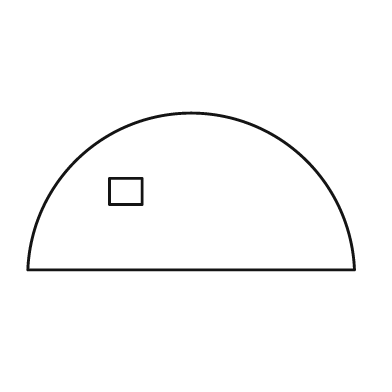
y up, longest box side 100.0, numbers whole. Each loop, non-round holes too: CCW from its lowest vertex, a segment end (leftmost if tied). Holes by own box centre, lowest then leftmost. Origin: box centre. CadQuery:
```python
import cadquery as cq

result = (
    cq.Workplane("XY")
    .moveTo(-50.0, -24.0)
    .lineTo(50.0, -24.0)
    .threePointArc((0.0, 24.0), (-50.0, -24.0))
    .close()
    .moveTo(-25.0, -4.0)
    .lineTo(-15.0, -4.0)
    .lineTo(-15.0, 4.0)
    .lineTo(-25.0, 4.0)
    .close()
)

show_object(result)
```